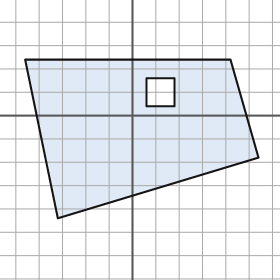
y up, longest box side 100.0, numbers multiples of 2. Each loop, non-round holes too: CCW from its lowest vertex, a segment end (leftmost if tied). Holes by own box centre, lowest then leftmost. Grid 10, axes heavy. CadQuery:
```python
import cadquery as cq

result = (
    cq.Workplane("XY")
    .moveTo(-32.0, -44.0)
    .lineTo(54.0, -18.0)
    .lineTo(42.0, 24.0)
    .lineTo(-46.0, 24.0)
    .close()
    .moveTo(6.0, 4.0)
    .lineTo(18.0, 4.0)
    .lineTo(18.0, 16.0)
    .lineTo(6.0, 16.0)
    .close()
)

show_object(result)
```